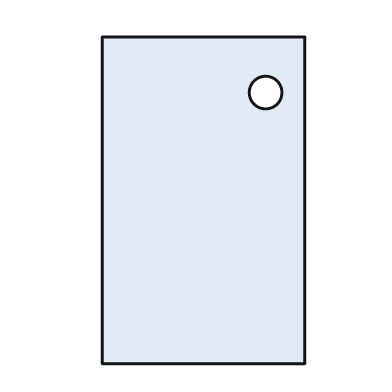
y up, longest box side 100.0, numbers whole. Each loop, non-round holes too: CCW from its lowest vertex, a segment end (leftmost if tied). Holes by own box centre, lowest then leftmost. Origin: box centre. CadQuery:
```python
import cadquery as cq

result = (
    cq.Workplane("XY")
    .moveTo(-31.0, -50.0)
    .lineTo(31.0, -50.0)
    .lineTo(31.0, 50.0)
    .lineTo(-31.0, 50.0)
    .close()
    .moveTo(19.0, 33.0)
    .circle(5.0)
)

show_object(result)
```